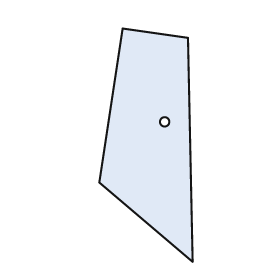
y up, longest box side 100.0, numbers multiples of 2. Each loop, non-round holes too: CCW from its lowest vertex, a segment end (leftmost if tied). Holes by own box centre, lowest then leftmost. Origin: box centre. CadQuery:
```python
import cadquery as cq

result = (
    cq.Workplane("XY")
    .moveTo(20.0, -50.0)
    .lineTo(18.0, 46.0)
    .lineTo(-10.0, 50.0)
    .lineTo(-20.0, -16.0)
    .close()
    .moveTo(8.0, 10.0)
    .circle(2.0)
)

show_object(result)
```